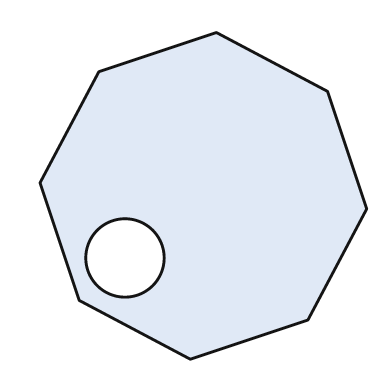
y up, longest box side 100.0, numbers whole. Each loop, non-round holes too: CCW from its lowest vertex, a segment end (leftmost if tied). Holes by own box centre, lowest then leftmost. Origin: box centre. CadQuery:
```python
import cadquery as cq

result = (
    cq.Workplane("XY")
    .moveTo(-4.0, -50.0)
    .lineTo(32.0, -38.0)
    .lineTo(50.0, -4.0)
    .lineTo(38.0, 32.0)
    .lineTo(4.0, 50.0)
    .lineTo(-32.0, 38.0)
    .lineTo(-50.0, 4.0)
    .lineTo(-38.0, -32.0)
    .close()
    .moveTo(-24.0, -19.0)
    .circle(12.0)
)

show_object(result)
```